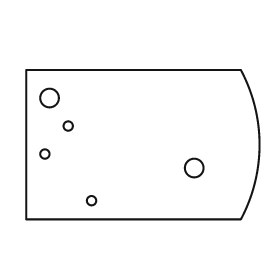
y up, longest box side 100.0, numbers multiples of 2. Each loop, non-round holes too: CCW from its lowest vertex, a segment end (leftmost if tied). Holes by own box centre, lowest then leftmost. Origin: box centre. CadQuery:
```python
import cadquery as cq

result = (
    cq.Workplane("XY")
    .moveTo(-50.0, -32.0)
    .lineTo(42.0, -32.0)
    .threePointArc((50.0, 0.0), (42.0, 32.0))
    .lineTo(-50.0, 32.0)
    .close()
    .moveTo(-22.0, -24.0)
    .circle(2.0)
    .moveTo(22.0, -10.0)
    .circle(4.0)
    .moveTo(-42.0, -4.0)
    .circle(2.0)
    .moveTo(-32.0, 8.0)
    .circle(2.0)
    .moveTo(-40.0, 20.0)
    .circle(4.0)
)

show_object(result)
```